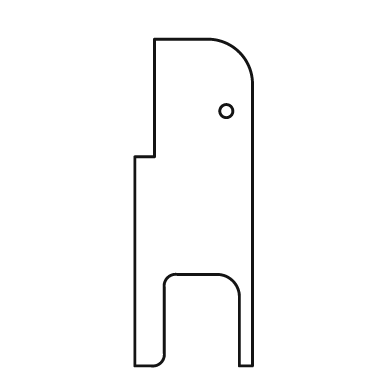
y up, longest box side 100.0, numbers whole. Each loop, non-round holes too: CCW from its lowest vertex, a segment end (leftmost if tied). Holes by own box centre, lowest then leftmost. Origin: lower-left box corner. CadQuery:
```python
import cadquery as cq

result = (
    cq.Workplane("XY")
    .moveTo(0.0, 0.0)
    .lineTo(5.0, 0.0)
    .threePointArc((8.0, 1.0), (9.0, 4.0))
    .lineTo(9.0, 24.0)
    .threePointArc((10.0, 27.0), (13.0, 28.0))
    .lineTo(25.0, 28.0)
    .threePointArc((30.0, 26.0), (32.0, 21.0))
    .lineTo(32.0, 0.0)
    .lineTo(36.0, 0.0)
    .lineTo(36.0, 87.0)
    .threePointArc((32.0, 96.0), (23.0, 100.0))
    .lineTo(6.0, 100.0)
    .lineTo(6.0, 64.0)
    .lineTo(0.0, 64.0)
    .close()
    .moveTo(28.0, 78.0)
    .circle(2.0)
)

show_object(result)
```